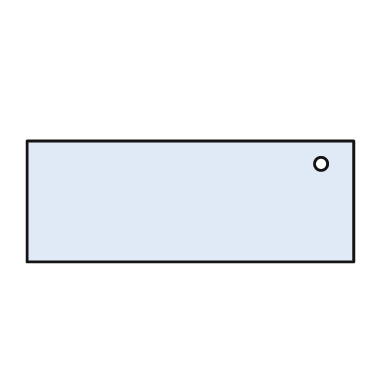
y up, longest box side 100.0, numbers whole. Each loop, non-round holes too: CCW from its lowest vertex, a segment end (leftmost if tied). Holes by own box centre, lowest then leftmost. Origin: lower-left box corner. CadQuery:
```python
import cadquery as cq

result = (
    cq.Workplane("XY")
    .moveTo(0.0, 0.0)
    .lineTo(100.0, 0.0)
    .lineTo(100.0, 37.0)
    .lineTo(0.0, 37.0)
    .close()
    .moveTo(90.0, 30.0)
    .circle(2.0)
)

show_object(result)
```